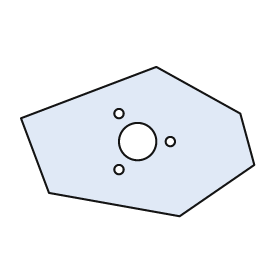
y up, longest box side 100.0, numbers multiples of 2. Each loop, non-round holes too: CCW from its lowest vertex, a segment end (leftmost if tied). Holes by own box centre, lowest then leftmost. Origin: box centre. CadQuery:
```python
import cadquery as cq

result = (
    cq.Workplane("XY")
    .moveTo(18.0, -32.0)
    .lineTo(50.0, -10.0)
    .lineTo(44.0, 12.0)
    .lineTo(8.0, 32.0)
    .lineTo(-50.0, 10.0)
    .lineTo(-38.0, -22.0)
    .close()
    .moveTo(-8.0, -12.0)
    .circle(2.0)
    .moveTo(0.0, 0.0)
    .circle(8.0)
    .moveTo(14.0, 0.0)
    .circle(2.0)
    .moveTo(-8.0, 12.0)
    .circle(2.0)
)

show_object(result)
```